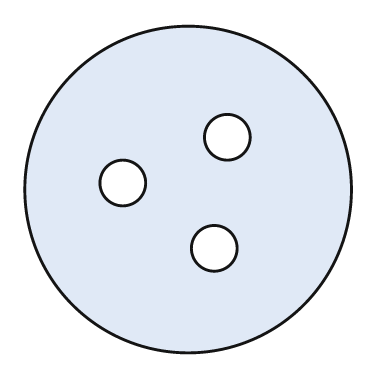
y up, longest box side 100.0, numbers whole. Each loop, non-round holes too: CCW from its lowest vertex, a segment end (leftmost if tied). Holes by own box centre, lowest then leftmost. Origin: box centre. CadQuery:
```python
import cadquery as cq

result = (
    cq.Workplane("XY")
    .moveTo(0.0, 0.0)
    .circle(50.0)
    .moveTo(8.0, -18.0)
    .circle(7.0)
    .moveTo(-20.0, 2.0)
    .circle(7.0)
    .moveTo(12.0, 16.0)
    .circle(7.0)
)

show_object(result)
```